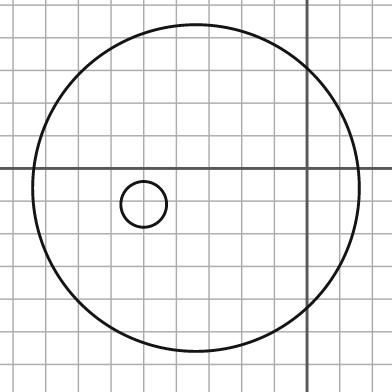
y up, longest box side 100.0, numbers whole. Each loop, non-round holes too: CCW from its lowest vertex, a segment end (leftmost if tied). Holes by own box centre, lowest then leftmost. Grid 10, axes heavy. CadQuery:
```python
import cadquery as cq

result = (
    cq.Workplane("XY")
    .moveTo(-34.0, -6.0)
    .circle(50.0)
    .moveTo(-50.0, -11.0)
    .circle(7.0)
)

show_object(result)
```